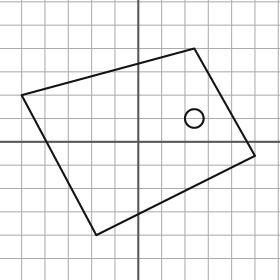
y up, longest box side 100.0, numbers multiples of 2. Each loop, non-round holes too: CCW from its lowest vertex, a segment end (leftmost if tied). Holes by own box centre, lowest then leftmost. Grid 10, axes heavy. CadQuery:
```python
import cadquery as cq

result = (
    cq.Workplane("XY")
    .moveTo(-18.0, -40.0)
    .lineTo(50.0, -6.0)
    .lineTo(24.0, 40.0)
    .lineTo(-50.0, 20.0)
    .close()
    .moveTo(24.0, 10.0)
    .circle(4.0)
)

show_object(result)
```